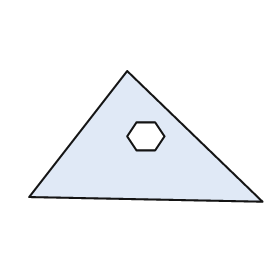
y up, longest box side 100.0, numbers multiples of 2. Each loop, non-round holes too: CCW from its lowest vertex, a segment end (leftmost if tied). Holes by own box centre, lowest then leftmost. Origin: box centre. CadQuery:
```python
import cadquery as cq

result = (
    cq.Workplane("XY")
    .moveTo(50.0, -28.0)
    .lineTo(-8.0, 28.0)
    .lineTo(-50.0, -26.0)
    .close()
    .moveTo(-4.0, -6.0)
    .lineTo(4.0, -6.0)
    .lineTo(8.0, 0.0)
    .lineTo(4.0, 6.0)
    .lineTo(-4.0, 6.0)
    .lineTo(-8.0, 0.0)
    .close()
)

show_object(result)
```